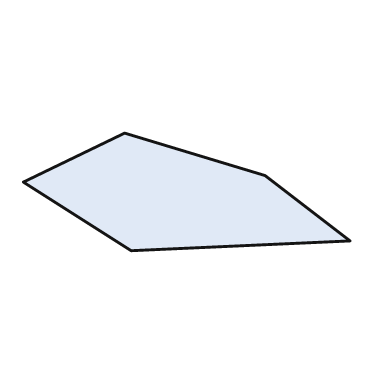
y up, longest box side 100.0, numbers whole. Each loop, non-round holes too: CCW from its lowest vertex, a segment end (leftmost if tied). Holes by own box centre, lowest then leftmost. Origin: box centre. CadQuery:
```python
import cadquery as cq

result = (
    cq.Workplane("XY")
    .moveTo(-17.0, -18.0)
    .lineTo(50.0, -15.0)
    .lineTo(24.0, 5.0)
    .lineTo(-19.0, 18.0)
    .lineTo(-50.0, 3.0)
    .close()
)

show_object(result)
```